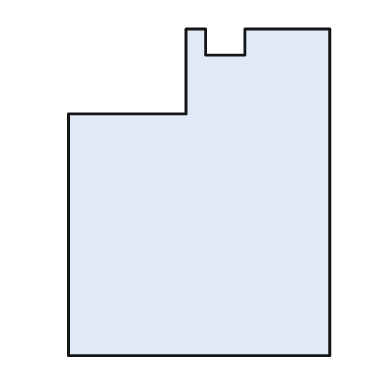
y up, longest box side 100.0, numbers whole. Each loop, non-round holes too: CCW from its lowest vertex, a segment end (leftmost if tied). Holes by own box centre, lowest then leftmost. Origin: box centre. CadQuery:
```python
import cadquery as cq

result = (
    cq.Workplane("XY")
    .moveTo(-40.0, -50.0)
    .lineTo(40.0, -50.0)
    .lineTo(40.0, 50.0)
    .lineTo(14.0, 50.0)
    .lineTo(14.0, 42.0)
    .lineTo(2.0, 42.0)
    .lineTo(2.0, 50.0)
    .lineTo(-4.0, 50.0)
    .lineTo(-4.0, 24.0)
    .lineTo(-40.0, 24.0)
    .close()
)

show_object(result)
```